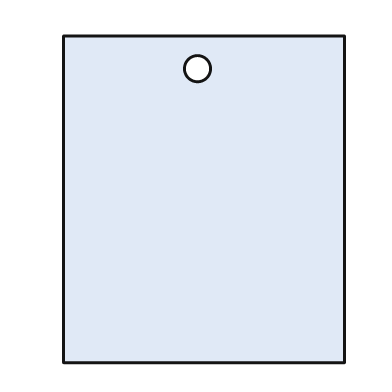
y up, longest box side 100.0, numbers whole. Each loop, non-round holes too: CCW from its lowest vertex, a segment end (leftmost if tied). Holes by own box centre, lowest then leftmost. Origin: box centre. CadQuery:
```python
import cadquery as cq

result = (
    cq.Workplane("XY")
    .moveTo(-43.0, -50.0)
    .lineTo(43.0, -50.0)
    .lineTo(43.0, 50.0)
    .lineTo(-43.0, 50.0)
    .close()
    .moveTo(-2.0, 40.0)
    .circle(4.0)
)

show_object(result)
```